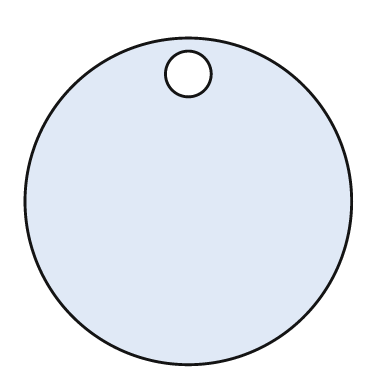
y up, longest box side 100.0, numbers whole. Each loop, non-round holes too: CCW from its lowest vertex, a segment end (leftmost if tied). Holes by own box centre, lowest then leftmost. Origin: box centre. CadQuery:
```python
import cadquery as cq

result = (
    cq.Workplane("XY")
    .moveTo(0.0, 0.0)
    .circle(50.0)
    .moveTo(0.0, 39.0)
    .circle(7.0)
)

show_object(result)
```